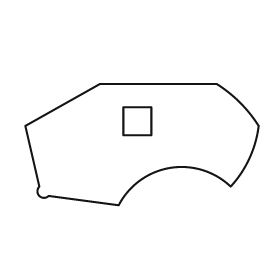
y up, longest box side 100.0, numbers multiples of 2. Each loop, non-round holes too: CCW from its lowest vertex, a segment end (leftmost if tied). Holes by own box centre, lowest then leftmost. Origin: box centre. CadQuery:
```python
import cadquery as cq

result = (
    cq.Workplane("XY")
    .moveTo(-10.0, -26.0)
    .threePointArc((12.0, -10.0), (38.0, -18.0))
    .threePointArc((46.0, -6.0), (50.0, 8.0))
    .threePointArc((42.0, 18.0), (32.0, 26.0))
    .lineTo(-18.0, 26.0)
    .lineTo(-50.0, 8.0)
    .lineTo(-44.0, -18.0)
    .threePointArc((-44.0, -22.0), (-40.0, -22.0))
    .close()
    .moveTo(-8.0, 4.0)
    .lineTo(4.0, 4.0)
    .lineTo(4.0, 16.0)
    .lineTo(-8.0, 16.0)
    .close()
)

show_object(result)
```